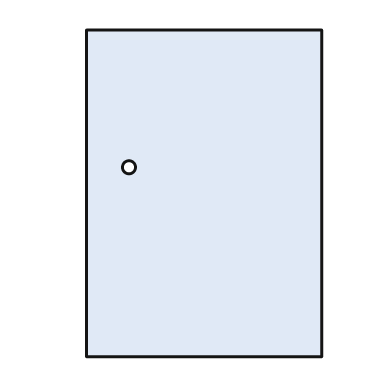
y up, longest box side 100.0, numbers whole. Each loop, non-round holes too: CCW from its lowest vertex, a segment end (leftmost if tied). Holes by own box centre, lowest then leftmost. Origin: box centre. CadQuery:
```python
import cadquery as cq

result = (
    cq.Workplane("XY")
    .moveTo(-36.0, -50.0)
    .lineTo(36.0, -50.0)
    .lineTo(36.0, 50.0)
    .lineTo(-36.0, 50.0)
    .close()
    .moveTo(-23.0, 8.0)
    .circle(2.0)
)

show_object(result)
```